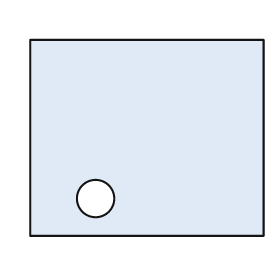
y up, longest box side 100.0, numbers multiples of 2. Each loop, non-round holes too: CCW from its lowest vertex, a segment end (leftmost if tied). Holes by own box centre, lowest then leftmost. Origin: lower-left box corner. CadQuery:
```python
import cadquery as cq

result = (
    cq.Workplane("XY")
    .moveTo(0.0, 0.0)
    .lineTo(100.0, 0.0)
    .lineTo(100.0, 84.0)
    .lineTo(0.0, 84.0)
    .close()
    .moveTo(28.0, 16.0)
    .circle(8.0)
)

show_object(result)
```